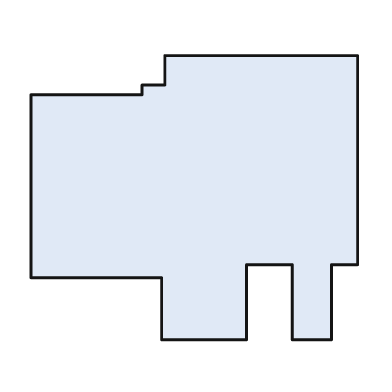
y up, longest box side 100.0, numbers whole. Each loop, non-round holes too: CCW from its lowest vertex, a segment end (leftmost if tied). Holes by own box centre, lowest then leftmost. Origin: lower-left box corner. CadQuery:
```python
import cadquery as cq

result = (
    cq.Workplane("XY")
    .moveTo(40.0, 0.0)
    .lineTo(66.0, 0.0)
    .lineTo(66.0, 23.0)
    .lineTo(80.0, 23.0)
    .lineTo(80.0, 0.0)
    .lineTo(92.0, 0.0)
    .lineTo(92.0, 23.0)
    .lineTo(100.0, 23.0)
    .lineTo(100.0, 87.0)
    .lineTo(41.0, 87.0)
    .lineTo(41.0, 78.0)
    .lineTo(34.0, 78.0)
    .lineTo(34.0, 75.0)
    .lineTo(0.0, 75.0)
    .lineTo(0.0, 19.0)
    .lineTo(40.0, 19.0)
    .close()
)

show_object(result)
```